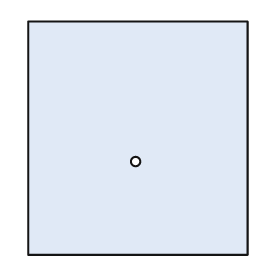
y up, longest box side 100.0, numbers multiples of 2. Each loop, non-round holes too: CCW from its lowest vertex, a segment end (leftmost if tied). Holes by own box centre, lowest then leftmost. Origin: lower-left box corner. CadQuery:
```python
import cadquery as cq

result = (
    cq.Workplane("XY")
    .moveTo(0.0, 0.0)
    .lineTo(94.0, 0.0)
    .lineTo(94.0, 100.0)
    .lineTo(0.0, 100.0)
    .close()
    .moveTo(46.0, 40.0)
    .circle(2.0)
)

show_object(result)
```